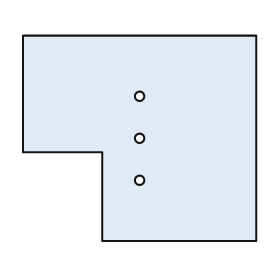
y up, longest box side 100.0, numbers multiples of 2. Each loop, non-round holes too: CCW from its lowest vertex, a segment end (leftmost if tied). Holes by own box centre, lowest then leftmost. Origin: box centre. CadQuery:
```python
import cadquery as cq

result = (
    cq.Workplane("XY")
    .moveTo(-16.0, -44.0)
    .lineTo(50.0, -44.0)
    .lineTo(50.0, 44.0)
    .lineTo(-50.0, 44.0)
    .lineTo(-50.0, -6.0)
    .lineTo(-16.0, -6.0)
    .close()
    .moveTo(0.0, -18.0)
    .circle(2.0)
    .moveTo(0.0, 0.0)
    .circle(2.0)
    .moveTo(0.0, 18.0)
    .circle(2.0)
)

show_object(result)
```